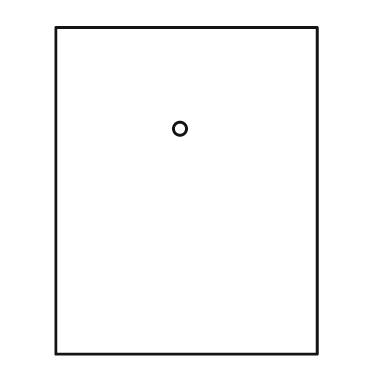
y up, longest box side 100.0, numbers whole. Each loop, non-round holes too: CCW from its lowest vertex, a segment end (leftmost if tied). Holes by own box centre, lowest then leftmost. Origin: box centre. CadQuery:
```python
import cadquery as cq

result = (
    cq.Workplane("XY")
    .moveTo(-40.0, -50.0)
    .lineTo(40.0, -50.0)
    .lineTo(40.0, 50.0)
    .lineTo(-40.0, 50.0)
    .close()
    .moveTo(-2.0, 19.0)
    .circle(2.0)
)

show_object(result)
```